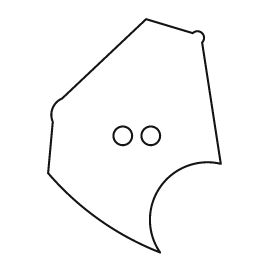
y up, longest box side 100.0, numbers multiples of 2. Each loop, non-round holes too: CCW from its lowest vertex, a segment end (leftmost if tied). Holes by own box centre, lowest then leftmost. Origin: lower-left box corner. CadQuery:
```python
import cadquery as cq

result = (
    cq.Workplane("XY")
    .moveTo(48.0, 0.0)
    .threePointArc((48.0, 28.0), (74.0, 38.0))
    .lineTo(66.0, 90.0)
    .threePointArc((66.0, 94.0), (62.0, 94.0))
    .lineTo(42.0, 100.0)
    .lineTo(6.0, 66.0)
    .threePointArc((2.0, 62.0), (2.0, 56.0))
    .lineTo(0.0, 34.0)
    .threePointArc((22.0, 14.0), (48.0, 0.0))
    .close()
    .moveTo(32.0, 50.0)
    .circle(4.0)
    .moveTo(44.0, 50.0)
    .circle(4.0)
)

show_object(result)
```